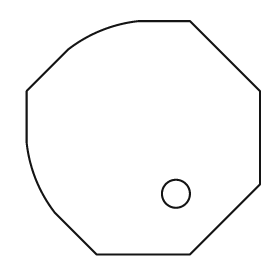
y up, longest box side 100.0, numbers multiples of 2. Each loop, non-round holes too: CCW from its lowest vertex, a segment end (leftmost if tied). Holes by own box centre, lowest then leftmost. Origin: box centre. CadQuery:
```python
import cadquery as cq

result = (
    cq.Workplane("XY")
    .moveTo(-20.0, -50.0)
    .lineTo(20.0, -50.0)
    .lineTo(50.0, -20.0)
    .lineTo(50.0, 20.0)
    .lineTo(20.0, 50.0)
    .lineTo(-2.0, 50.0)
    .threePointArc((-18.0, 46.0), (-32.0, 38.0))
    .lineTo(-50.0, 20.0)
    .lineTo(-50.0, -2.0)
    .threePointArc((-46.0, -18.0), (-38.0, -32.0))
    .close()
    .moveTo(14.0, -24.0)
    .circle(6.0)
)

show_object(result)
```